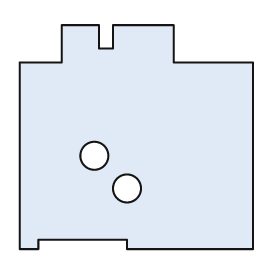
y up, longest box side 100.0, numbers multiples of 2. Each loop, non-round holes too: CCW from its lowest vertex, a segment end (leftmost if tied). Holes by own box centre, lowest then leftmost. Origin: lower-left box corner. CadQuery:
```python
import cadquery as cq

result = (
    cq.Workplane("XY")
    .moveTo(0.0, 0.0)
    .lineTo(8.0, 0.0)
    .lineTo(8.0, 4.0)
    .lineTo(46.0, 4.0)
    .lineTo(46.0, 0.0)
    .lineTo(100.0, 0.0)
    .lineTo(100.0, 80.0)
    .lineTo(66.0, 80.0)
    .lineTo(66.0, 96.0)
    .lineTo(40.0, 96.0)
    .lineTo(40.0, 86.0)
    .lineTo(34.0, 86.0)
    .lineTo(34.0, 96.0)
    .lineTo(18.0, 96.0)
    .lineTo(18.0, 80.0)
    .lineTo(0.0, 80.0)
    .close()
    .moveTo(46.0, 26.0)
    .circle(6.0)
    .moveTo(32.0, 40.0)
    .circle(6.0)
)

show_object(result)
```